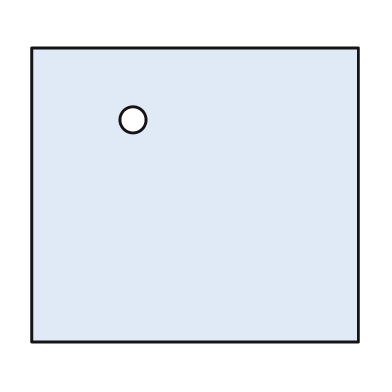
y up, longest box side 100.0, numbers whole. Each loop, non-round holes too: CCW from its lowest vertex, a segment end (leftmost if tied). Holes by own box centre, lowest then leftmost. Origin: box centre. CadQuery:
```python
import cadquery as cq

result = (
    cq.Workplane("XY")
    .moveTo(-50.0, -45.0)
    .lineTo(50.0, -45.0)
    .lineTo(50.0, 45.0)
    .lineTo(-50.0, 45.0)
    .close()
    .moveTo(-19.0, 23.0)
    .circle(4.0)
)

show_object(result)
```